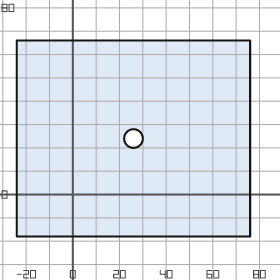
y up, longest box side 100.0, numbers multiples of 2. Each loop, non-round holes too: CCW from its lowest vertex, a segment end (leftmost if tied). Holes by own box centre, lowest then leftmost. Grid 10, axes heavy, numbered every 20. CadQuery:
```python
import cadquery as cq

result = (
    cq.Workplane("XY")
    .moveTo(-24.0, -18.0)
    .lineTo(76.0, -18.0)
    .lineTo(76.0, 66.0)
    .lineTo(-24.0, 66.0)
    .close()
    .moveTo(26.0, 24.0)
    .circle(4.0)
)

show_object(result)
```